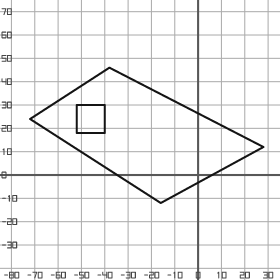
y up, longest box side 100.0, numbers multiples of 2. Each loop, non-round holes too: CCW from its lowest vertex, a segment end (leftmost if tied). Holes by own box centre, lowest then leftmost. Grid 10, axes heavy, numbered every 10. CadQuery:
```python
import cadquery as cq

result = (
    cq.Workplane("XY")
    .moveTo(-16.0, -12.0)
    .lineTo(28.0, 12.0)
    .lineTo(-38.0, 46.0)
    .lineTo(-72.0, 24.0)
    .close()
    .moveTo(-52.0, 18.0)
    .lineTo(-40.0, 18.0)
    .lineTo(-40.0, 30.0)
    .lineTo(-52.0, 30.0)
    .close()
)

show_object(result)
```